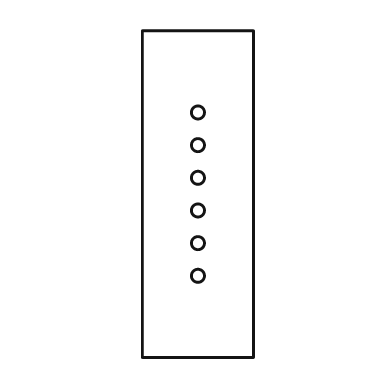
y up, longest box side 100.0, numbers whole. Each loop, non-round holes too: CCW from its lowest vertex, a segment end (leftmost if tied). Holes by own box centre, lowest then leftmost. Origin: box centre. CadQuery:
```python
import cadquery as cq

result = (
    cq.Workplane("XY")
    .moveTo(-17.0, -50.0)
    .lineTo(17.0, -50.0)
    .lineTo(17.0, 50.0)
    .lineTo(-17.0, 50.0)
    .close()
    .moveTo(0.0, -25.0)
    .circle(2.0)
    .moveTo(0.0, -15.0)
    .circle(2.0)
    .moveTo(0.0, -5.0)
    .circle(2.0)
    .moveTo(0.0, 5.0)
    .circle(2.0)
    .moveTo(0.0, 15.0)
    .circle(2.0)
    .moveTo(0.0, 25.0)
    .circle(2.0)
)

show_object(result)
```